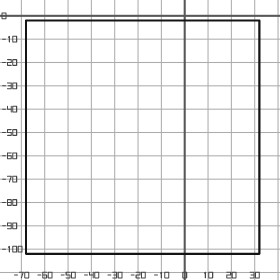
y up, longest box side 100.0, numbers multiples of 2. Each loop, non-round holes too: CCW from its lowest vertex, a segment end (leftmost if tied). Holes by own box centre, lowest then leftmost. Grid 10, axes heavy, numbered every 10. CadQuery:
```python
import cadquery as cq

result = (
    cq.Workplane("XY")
    .moveTo(-68.0, -102.0)
    .lineTo(32.0, -102.0)
    .lineTo(32.0, -2.0)
    .lineTo(-68.0, -2.0)
    .close()
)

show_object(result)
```